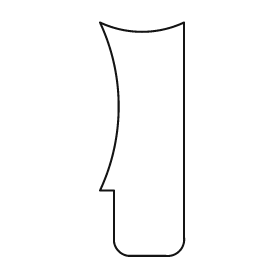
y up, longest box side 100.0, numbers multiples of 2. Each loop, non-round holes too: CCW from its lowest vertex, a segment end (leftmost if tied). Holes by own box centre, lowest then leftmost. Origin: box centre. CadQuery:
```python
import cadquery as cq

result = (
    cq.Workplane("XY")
    .moveTo(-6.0, -50.0)
    .lineTo(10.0, -50.0)
    .threePointArc((16.0, -48.0), (18.0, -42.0))
    .lineTo(18.0, 50.0)
    .threePointArc((0.0, 46.0), (-18.0, 50.0))
    .threePointArc((-10.0, 14.0), (-18.0, -22.0))
    .lineTo(-12.0, -22.0)
    .lineTo(-12.0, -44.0)
    .threePointArc((-10.0, -48.0), (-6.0, -50.0))
    .close()
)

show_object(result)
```